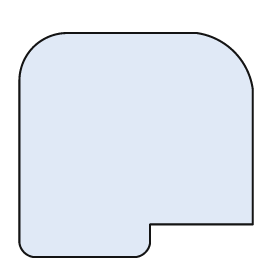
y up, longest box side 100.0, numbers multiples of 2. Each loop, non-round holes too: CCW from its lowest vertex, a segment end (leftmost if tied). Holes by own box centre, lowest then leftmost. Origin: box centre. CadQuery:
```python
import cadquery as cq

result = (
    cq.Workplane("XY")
    .moveTo(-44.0, -48.0)
    .lineTo(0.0, -48.0)
    .threePointArc((4.0, -46.0), (6.0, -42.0))
    .lineTo(6.0, -34.0)
    .lineTo(50.0, -34.0)
    .lineTo(50.0, 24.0)
    .threePointArc((42.0, 40.0), (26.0, 48.0))
    .lineTo(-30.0, 48.0)
    .threePointArc((-44.0, 42.0), (-50.0, 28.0))
    .lineTo(-50.0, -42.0)
    .threePointArc((-48.0, -46.0), (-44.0, -48.0))
    .close()
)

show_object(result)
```